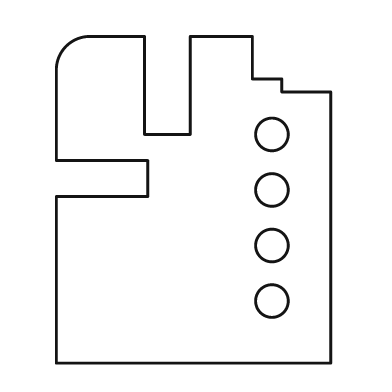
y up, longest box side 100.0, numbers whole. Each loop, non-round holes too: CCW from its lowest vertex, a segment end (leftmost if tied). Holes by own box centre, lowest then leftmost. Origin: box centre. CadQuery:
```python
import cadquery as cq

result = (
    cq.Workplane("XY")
    .moveTo(-42.0, -50.0)
    .lineTo(42.0, -50.0)
    .lineTo(42.0, 33.0)
    .lineTo(27.0, 33.0)
    .lineTo(27.0, 37.0)
    .lineTo(18.0, 37.0)
    .lineTo(18.0, 50.0)
    .lineTo(-1.0, 50.0)
    .lineTo(-1.0, 20.0)
    .lineTo(-15.0, 20.0)
    .lineTo(-15.0, 50.0)
    .lineTo(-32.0, 50.0)
    .threePointArc((-39.0, 47.0), (-42.0, 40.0))
    .lineTo(-42.0, 12.0)
    .lineTo(-14.0, 12.0)
    .lineTo(-14.0, 1.0)
    .lineTo(-42.0, 1.0)
    .close()
    .moveTo(24.0, -31.0)
    .circle(5.0)
    .moveTo(24.0, -14.0)
    .circle(5.0)
    .moveTo(24.0, 3.0)
    .circle(5.0)
    .moveTo(24.0, 20.0)
    .circle(5.0)
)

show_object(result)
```